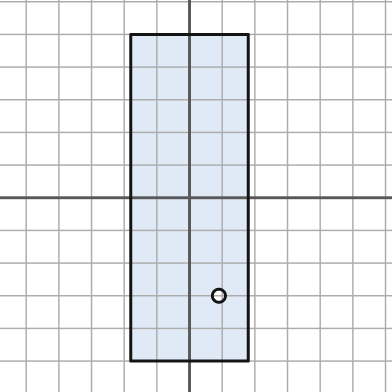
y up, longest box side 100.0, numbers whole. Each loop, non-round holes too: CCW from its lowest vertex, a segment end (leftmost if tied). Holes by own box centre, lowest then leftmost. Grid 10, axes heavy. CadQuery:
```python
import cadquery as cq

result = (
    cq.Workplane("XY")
    .moveTo(-18.0, -50.0)
    .lineTo(18.0, -50.0)
    .lineTo(18.0, 50.0)
    .lineTo(-18.0, 50.0)
    .close()
    .moveTo(9.0, -30.0)
    .circle(2.0)
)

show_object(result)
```